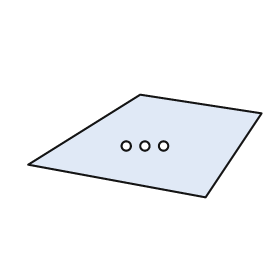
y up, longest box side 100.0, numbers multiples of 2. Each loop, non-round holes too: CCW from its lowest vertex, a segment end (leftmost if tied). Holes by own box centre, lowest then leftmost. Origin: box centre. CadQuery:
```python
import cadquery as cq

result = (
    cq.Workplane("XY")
    .moveTo(26.0, -22.0)
    .lineTo(50.0, 14.0)
    .lineTo(-2.0, 22.0)
    .lineTo(-50.0, -8.0)
    .close()
    .moveTo(-8.0, 0.0)
    .circle(2.0)
    .moveTo(0.0, 0.0)
    .circle(2.0)
    .moveTo(8.0, 0.0)
    .circle(2.0)
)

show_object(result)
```